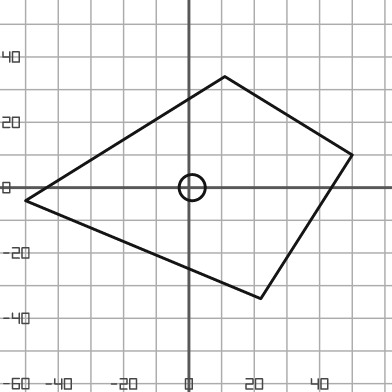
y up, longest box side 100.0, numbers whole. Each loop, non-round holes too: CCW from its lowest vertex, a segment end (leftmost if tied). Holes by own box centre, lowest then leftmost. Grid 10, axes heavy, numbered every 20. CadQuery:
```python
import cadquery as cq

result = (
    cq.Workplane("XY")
    .moveTo(22.0, -34.0)
    .lineTo(50.0, 10.0)
    .lineTo(11.0, 34.0)
    .lineTo(-50.0, -4.0)
    .close()
    .moveTo(1.0, 0.0)
    .circle(4.0)
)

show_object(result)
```